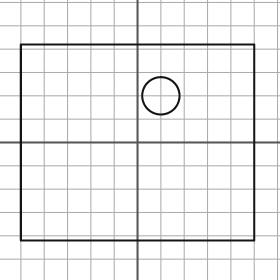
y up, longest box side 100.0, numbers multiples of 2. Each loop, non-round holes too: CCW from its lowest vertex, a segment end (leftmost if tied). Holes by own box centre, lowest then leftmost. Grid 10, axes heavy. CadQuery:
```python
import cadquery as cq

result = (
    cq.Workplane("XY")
    .moveTo(-50.0, -42.0)
    .lineTo(50.0, -42.0)
    .lineTo(50.0, 42.0)
    .lineTo(-50.0, 42.0)
    .close()
    .moveTo(10.0, 20.0)
    .circle(8.0)
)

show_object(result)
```